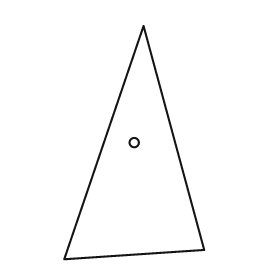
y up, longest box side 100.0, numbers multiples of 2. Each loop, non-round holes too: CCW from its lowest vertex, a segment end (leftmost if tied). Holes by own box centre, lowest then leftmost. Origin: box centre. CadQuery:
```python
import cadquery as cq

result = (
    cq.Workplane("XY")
    .moveTo(-30.0, -50.0)
    .lineTo(30.0, -46.0)
    .lineTo(4.0, 50.0)
    .close()
    .moveTo(0.0, 0.0)
    .circle(2.0)
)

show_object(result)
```